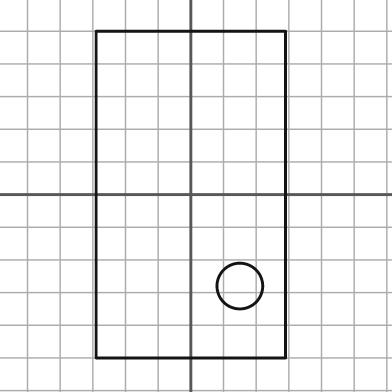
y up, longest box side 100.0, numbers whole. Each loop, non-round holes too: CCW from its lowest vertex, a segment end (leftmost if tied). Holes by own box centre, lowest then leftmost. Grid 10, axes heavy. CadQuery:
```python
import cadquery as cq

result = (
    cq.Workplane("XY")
    .moveTo(-29.0, -50.0)
    .lineTo(29.0, -50.0)
    .lineTo(29.0, 50.0)
    .lineTo(-29.0, 50.0)
    .close()
    .moveTo(15.0, -28.0)
    .circle(7.0)
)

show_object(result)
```